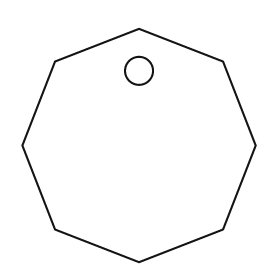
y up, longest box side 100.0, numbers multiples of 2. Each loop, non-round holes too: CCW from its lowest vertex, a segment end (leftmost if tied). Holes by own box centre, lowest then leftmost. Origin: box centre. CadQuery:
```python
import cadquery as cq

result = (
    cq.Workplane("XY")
    .moveTo(0.0, -50.0)
    .lineTo(36.0, -36.0)
    .lineTo(50.0, 0.0)
    .lineTo(36.0, 36.0)
    .lineTo(0.0, 50.0)
    .lineTo(-36.0, 36.0)
    .lineTo(-50.0, 0.0)
    .lineTo(-36.0, -36.0)
    .close()
    .moveTo(0.0, 32.0)
    .circle(6.0)
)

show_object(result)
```